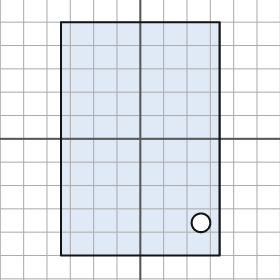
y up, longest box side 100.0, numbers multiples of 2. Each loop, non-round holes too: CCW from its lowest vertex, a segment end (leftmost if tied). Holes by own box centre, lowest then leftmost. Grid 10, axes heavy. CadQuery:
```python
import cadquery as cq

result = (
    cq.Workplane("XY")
    .moveTo(-34.0, -50.0)
    .lineTo(34.0, -50.0)
    .lineTo(34.0, 50.0)
    .lineTo(-34.0, 50.0)
    .close()
    .moveTo(26.0, -36.0)
    .circle(4.0)
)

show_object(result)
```